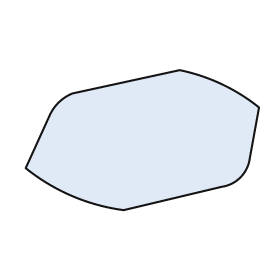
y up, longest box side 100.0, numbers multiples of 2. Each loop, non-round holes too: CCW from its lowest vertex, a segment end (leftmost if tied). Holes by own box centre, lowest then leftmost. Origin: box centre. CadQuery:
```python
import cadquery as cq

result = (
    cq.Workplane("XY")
    .moveTo(-8.0, -30.0)
    .lineTo(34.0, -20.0)
    .threePointArc((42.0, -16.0), (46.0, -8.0))
    .lineTo(50.0, 14.0)
    .threePointArc((34.0, 24.0), (16.0, 30.0))
    .lineTo(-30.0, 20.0)
    .threePointArc((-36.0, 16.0), (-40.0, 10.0))
    .lineTo(-50.0, -12.0)
    .threePointArc((-30.0, -24.0), (-8.0, -30.0))
    .close()
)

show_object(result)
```